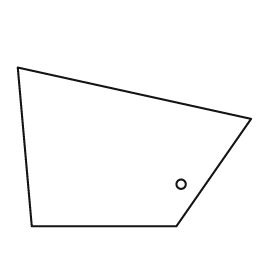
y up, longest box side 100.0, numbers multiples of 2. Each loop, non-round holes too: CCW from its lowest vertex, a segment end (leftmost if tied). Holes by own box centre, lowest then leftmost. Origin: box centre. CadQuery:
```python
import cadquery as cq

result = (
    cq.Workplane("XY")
    .moveTo(-44.0, -34.0)
    .lineTo(18.0, -34.0)
    .lineTo(50.0, 12.0)
    .lineTo(-50.0, 34.0)
    .close()
    .moveTo(20.0, -16.0)
    .circle(2.0)
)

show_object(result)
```